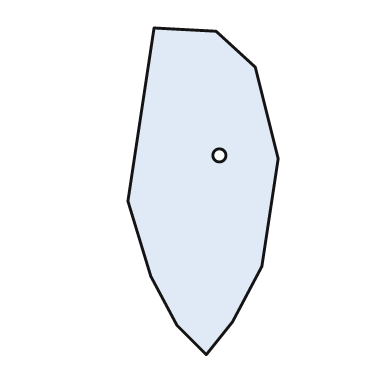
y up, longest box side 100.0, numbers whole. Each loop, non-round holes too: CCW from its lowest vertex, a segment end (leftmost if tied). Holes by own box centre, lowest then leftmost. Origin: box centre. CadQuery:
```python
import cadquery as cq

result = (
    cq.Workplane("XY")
    .moveTo(1.0, -50.0)
    .lineTo(9.0, -40.0)
    .lineTo(18.0, -23.0)
    .lineTo(23.0, 10.0)
    .lineTo(16.0, 38.0)
    .lineTo(4.0, 49.0)
    .lineTo(-15.0, 50.0)
    .lineTo(-23.0, -3.0)
    .lineTo(-16.0, -26.0)
    .lineTo(-8.0, -41.0)
    .close()
    .moveTo(5.0, 11.0)
    .circle(2.0)
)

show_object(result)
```